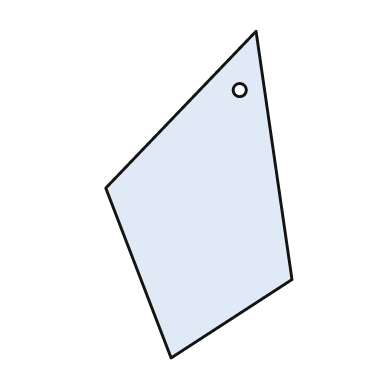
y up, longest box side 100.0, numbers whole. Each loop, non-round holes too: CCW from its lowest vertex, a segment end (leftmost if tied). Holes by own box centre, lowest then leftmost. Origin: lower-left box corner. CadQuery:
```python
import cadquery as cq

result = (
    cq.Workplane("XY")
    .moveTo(20.0, 0.0)
    .lineTo(57.0, 24.0)
    .lineTo(46.0, 100.0)
    .lineTo(0.0, 52.0)
    .close()
    .moveTo(41.0, 82.0)
    .circle(2.0)
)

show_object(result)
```